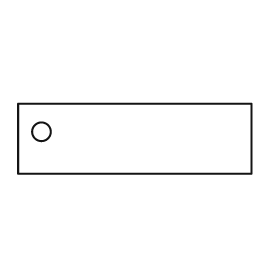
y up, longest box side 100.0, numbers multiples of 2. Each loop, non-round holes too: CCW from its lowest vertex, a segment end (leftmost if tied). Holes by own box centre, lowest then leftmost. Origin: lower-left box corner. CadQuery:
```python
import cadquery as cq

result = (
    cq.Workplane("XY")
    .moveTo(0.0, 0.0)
    .lineTo(100.0, 0.0)
    .lineTo(100.0, 30.0)
    .lineTo(0.0, 30.0)
    .close()
    .moveTo(10.0, 18.0)
    .circle(4.0)
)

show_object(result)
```